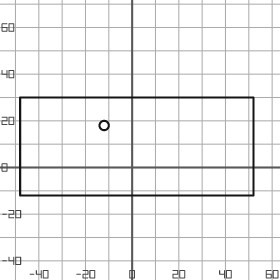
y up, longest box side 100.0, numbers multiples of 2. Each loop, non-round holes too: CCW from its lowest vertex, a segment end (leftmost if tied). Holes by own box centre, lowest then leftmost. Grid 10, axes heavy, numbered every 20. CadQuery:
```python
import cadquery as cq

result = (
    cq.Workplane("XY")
    .moveTo(-48.0, -12.0)
    .lineTo(52.0, -12.0)
    .lineTo(52.0, 30.0)
    .lineTo(-48.0, 30.0)
    .close()
    .moveTo(-12.0, 18.0)
    .circle(2.0)
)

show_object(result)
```